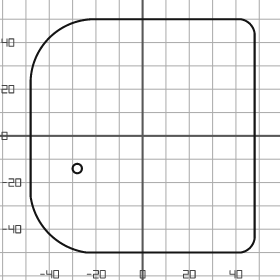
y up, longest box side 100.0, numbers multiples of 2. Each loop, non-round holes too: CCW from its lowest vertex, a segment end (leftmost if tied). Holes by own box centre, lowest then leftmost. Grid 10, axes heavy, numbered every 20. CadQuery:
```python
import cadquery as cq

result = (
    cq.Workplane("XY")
    .moveTo(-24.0, -50.0)
    .lineTo(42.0, -50.0)
    .threePointArc((46.0, -48.0), (48.0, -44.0))
    .lineTo(48.0, 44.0)
    .threePointArc((46.0, 48.0), (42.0, 50.0))
    .lineTo(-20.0, 50.0)
    .threePointArc((-40.0, 42.0), (-48.0, 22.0))
    .lineTo(-48.0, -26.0)
    .threePointArc((-40.0, -42.0), (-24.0, -50.0))
    .close()
    .moveTo(-28.0, -14.0)
    .circle(2.0)
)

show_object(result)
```